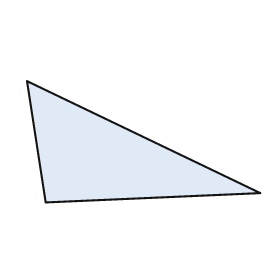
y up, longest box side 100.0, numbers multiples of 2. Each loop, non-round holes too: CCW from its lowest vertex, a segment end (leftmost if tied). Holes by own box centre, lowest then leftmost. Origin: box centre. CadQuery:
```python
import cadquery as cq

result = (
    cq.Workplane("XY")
    .moveTo(-42.0, -26.0)
    .lineTo(50.0, -22.0)
    .lineTo(-50.0, 26.0)
    .close()
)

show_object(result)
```